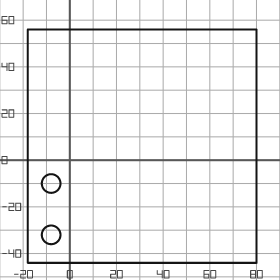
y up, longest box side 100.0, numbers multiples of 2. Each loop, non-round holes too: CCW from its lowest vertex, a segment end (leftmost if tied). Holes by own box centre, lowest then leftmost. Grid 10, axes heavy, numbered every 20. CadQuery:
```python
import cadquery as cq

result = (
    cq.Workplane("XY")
    .moveTo(-18.0, -44.0)
    .lineTo(80.0, -44.0)
    .lineTo(80.0, 56.0)
    .lineTo(-18.0, 56.0)
    .close()
    .moveTo(-8.0, -32.0)
    .circle(4.0)
    .moveTo(-8.0, -10.0)
    .circle(4.0)
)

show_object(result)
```